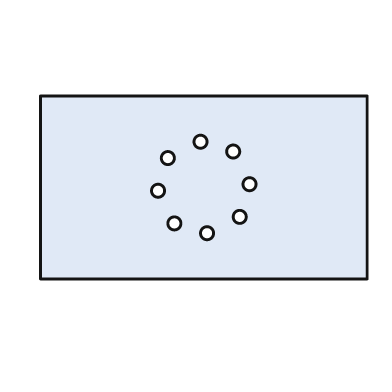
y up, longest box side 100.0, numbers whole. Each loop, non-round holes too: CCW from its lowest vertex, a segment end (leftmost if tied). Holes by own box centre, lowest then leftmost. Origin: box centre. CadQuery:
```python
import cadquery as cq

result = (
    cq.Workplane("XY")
    .moveTo(-50.0, -28.0)
    .lineTo(50.0, -28.0)
    .lineTo(50.0, 28.0)
    .lineTo(-50.0, 28.0)
    .close()
    .moveTo(1.0, -14.0)
    .circle(2.0)
    .moveTo(-9.0, -11.0)
    .circle(2.0)
    .moveTo(11.0, -9.0)
    .circle(2.0)
    .moveTo(-14.0, -1.0)
    .circle(2.0)
    .moveTo(14.0, 1.0)
    .circle(2.0)
    .moveTo(-11.0, 9.0)
    .circle(2.0)
    .moveTo(9.0, 11.0)
    .circle(2.0)
    .moveTo(-1.0, 14.0)
    .circle(2.0)
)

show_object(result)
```